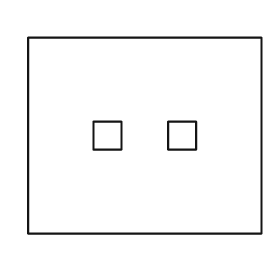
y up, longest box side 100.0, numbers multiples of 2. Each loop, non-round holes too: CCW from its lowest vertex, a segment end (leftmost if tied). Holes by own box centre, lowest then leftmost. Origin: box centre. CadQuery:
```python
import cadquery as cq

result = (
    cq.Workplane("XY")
    .moveTo(-50.0, -42.0)
    .lineTo(50.0, -42.0)
    .lineTo(50.0, 42.0)
    .lineTo(-50.0, 42.0)
    .close()
    .moveTo(-22.0, -6.0)
    .lineTo(-10.0, -6.0)
    .lineTo(-10.0, 6.0)
    .lineTo(-22.0, 6.0)
    .close()
    .moveTo(10.0, -6.0)
    .lineTo(22.0, -6.0)
    .lineTo(22.0, 6.0)
    .lineTo(10.0, 6.0)
    .close()
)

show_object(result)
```